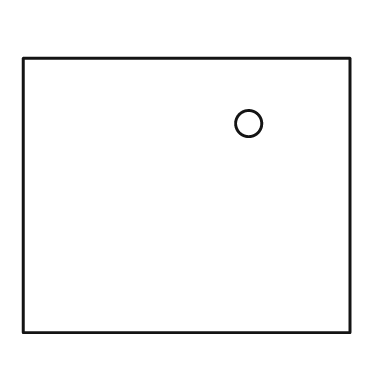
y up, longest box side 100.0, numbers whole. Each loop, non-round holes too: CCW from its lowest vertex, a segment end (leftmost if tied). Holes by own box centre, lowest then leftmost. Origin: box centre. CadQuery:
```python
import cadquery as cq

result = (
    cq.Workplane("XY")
    .moveTo(-50.0, -42.0)
    .lineTo(50.0, -42.0)
    .lineTo(50.0, 42.0)
    .lineTo(-50.0, 42.0)
    .close()
    .moveTo(19.0, 22.0)
    .circle(4.0)
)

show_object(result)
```